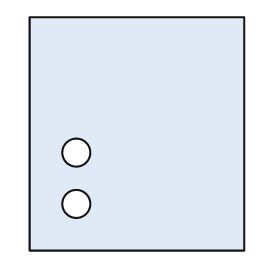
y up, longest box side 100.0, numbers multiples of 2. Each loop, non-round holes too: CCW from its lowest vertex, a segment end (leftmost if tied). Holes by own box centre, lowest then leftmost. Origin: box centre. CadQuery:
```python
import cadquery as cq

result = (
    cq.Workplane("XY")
    .moveTo(-46.0, -50.0)
    .lineTo(46.0, -50.0)
    .lineTo(46.0, 50.0)
    .lineTo(-46.0, 50.0)
    .close()
    .moveTo(-26.0, -30.0)
    .circle(6.0)
    .moveTo(-26.0, -8.0)
    .circle(6.0)
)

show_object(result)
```